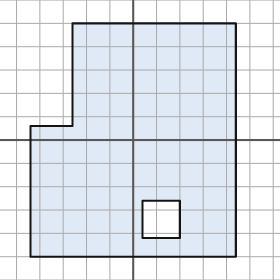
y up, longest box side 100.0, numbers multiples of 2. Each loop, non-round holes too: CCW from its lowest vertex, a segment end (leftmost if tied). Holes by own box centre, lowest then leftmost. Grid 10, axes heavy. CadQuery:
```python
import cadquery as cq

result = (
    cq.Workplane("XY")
    .moveTo(-44.0, -50.0)
    .lineTo(44.0, -50.0)
    .lineTo(44.0, 50.0)
    .lineTo(-26.0, 50.0)
    .lineTo(-26.0, 6.0)
    .lineTo(-44.0, 6.0)
    .close()
    .moveTo(4.0, -42.0)
    .lineTo(20.0, -42.0)
    .lineTo(20.0, -26.0)
    .lineTo(4.0, -26.0)
    .close()
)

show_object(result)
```